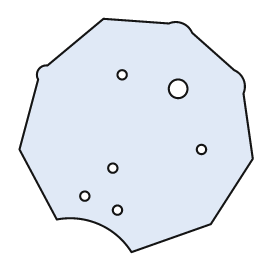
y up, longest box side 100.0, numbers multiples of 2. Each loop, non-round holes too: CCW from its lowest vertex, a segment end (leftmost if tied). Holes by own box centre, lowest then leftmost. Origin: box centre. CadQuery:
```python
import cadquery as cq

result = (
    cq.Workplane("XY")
    .moveTo(-2.0, -50.0)
    .lineTo(32.0, -38.0)
    .lineTo(50.0, -10.0)
    .lineTo(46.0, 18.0)
    .threePointArc((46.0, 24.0), (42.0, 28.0))
    .lineTo(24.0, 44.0)
    .threePointArc((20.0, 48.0), (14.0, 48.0))
    .lineTo(-14.0, 50.0)
    .lineTo(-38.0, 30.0)
    .threePointArc((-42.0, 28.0), (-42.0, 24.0))
    .lineTo(-50.0, -6.0)
    .lineTo(-34.0, -36.0)
    .threePointArc((-16.0, -38.0), (-2.0, -50.0))
    .close()
    .moveTo(-8.0, -32.0)
    .circle(2.0)
    .moveTo(-22.0, -26.0)
    .circle(2.0)
    .moveTo(-10.0, -14.0)
    .circle(2.0)
    .moveTo(28.0, -6.0)
    .circle(2.0)
    .moveTo(18.0, 20.0)
    .circle(4.0)
    .moveTo(-6.0, 26.0)
    .circle(2.0)
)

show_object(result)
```